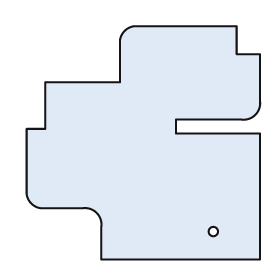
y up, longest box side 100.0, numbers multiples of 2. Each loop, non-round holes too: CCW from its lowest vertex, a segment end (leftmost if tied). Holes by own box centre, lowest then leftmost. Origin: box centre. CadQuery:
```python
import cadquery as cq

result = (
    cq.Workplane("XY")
    .moveTo(-18.0, -50.0)
    .lineTo(50.0, -50.0)
    .lineTo(50.0, 4.0)
    .lineTo(14.0, 4.0)
    .lineTo(14.0, 10.0)
    .lineTo(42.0, 10.0)
    .threePointArc((48.0, 12.0), (50.0, 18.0))
    .lineTo(50.0, 38.0)
    .lineTo(40.0, 38.0)
    .lineTo(40.0, 50.0)
    .lineTo(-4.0, 50.0)
    .threePointArc((-8.0, 48.0), (-10.0, 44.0))
    .lineTo(-10.0, 26.0)
    .lineTo(-42.0, 26.0)
    .lineTo(-42.0, 6.0)
    .lineTo(-50.0, 6.0)
    .lineTo(-50.0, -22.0)
    .threePointArc((-48.0, -26.0), (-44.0, -28.0))
    .lineTo(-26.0, -28.0)
    .threePointArc((-20.0, -30.0), (-18.0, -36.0))
    .close()
    .moveTo(30.0, -38.0)
    .circle(2.0)
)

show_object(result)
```